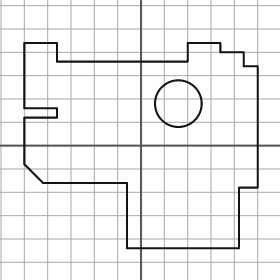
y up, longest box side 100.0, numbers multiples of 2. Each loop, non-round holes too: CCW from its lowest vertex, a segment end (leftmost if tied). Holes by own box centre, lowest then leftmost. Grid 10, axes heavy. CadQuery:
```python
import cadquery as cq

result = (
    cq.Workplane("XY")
    .moveTo(-6.0, -44.0)
    .lineTo(42.0, -44.0)
    .lineTo(42.0, -18.0)
    .lineTo(50.0, -18.0)
    .lineTo(50.0, 34.0)
    .lineTo(44.0, 34.0)
    .lineTo(44.0, 40.0)
    .lineTo(34.0, 40.0)
    .lineTo(34.0, 44.0)
    .lineTo(20.0, 44.0)
    .lineTo(20.0, 36.0)
    .lineTo(-36.0, 36.0)
    .lineTo(-36.0, 44.0)
    .lineTo(-50.0, 44.0)
    .lineTo(-50.0, 16.0)
    .lineTo(-36.0, 16.0)
    .lineTo(-36.0, 12.0)
    .lineTo(-50.0, 12.0)
    .lineTo(-50.0, -8.0)
    .lineTo(-42.0, -16.0)
    .lineTo(-6.0, -16.0)
    .close()
    .moveTo(16.0, 18.0)
    .circle(10.0)
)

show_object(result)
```